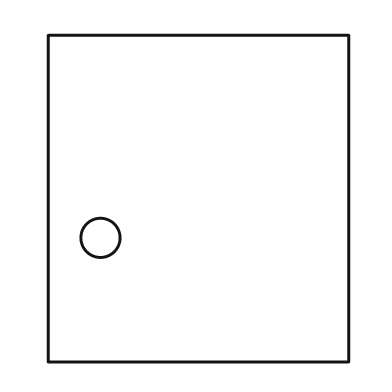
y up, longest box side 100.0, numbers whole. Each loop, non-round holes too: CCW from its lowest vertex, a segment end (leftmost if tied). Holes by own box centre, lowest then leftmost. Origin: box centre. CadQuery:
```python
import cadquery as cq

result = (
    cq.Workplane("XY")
    .moveTo(-46.0, -50.0)
    .lineTo(46.0, -50.0)
    .lineTo(46.0, 50.0)
    .lineTo(-46.0, 50.0)
    .close()
    .moveTo(-30.0, -12.0)
    .circle(6.0)
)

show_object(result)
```